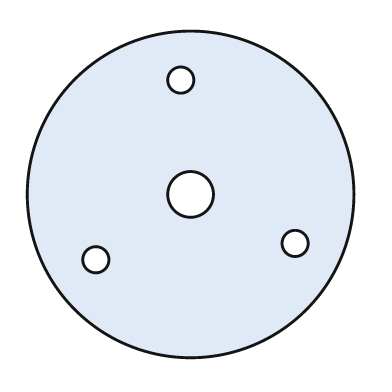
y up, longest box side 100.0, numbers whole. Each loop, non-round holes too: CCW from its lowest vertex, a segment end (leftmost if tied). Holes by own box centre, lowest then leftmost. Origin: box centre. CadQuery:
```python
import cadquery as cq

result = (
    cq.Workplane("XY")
    .moveTo(0.0, 0.0)
    .circle(50.0)
    .moveTo(-29.0, -20.0)
    .circle(4.0)
    .moveTo(32.0, -15.0)
    .circle(4.0)
    .moveTo(0.0, 0.0)
    .circle(7.0)
    .moveTo(-3.0, 35.0)
    .circle(4.0)
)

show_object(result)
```